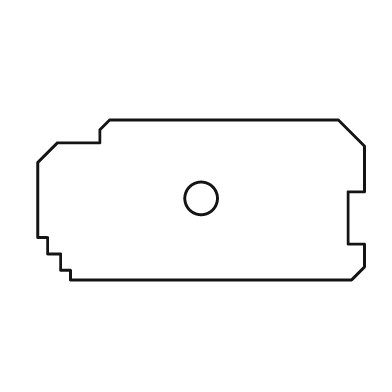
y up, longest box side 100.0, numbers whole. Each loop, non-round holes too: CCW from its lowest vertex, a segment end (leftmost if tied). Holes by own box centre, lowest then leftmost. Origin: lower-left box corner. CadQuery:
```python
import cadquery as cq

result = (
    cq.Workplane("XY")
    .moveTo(10.0, 0.0)
    .lineTo(96.0, 0.0)
    .lineTo(100.0, 4.0)
    .lineTo(100.0, 11.0)
    .lineTo(95.0, 11.0)
    .lineTo(95.0, 27.0)
    .lineTo(100.0, 27.0)
    .lineTo(100.0, 41.0)
    .lineTo(92.0, 49.0)
    .lineTo(22.0, 49.0)
    .lineTo(19.0, 46.0)
    .lineTo(19.0, 42.0)
    .lineTo(6.0, 42.0)
    .lineTo(0.0, 36.0)
    .lineTo(0.0, 13.0)
    .lineTo(3.0, 13.0)
    .lineTo(3.0, 8.0)
    .lineTo(7.0, 8.0)
    .lineTo(7.0, 3.0)
    .lineTo(10.0, 3.0)
    .close()
    .moveTo(50.0, 25.0)
    .circle(5.0)
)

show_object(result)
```